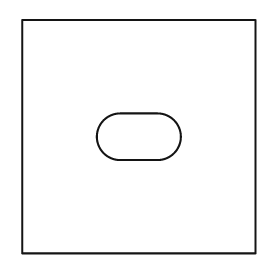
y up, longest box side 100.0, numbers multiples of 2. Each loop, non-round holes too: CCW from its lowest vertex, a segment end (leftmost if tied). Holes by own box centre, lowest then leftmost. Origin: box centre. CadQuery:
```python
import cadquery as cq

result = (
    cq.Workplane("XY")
    .moveTo(-50.0, -50.0)
    .lineTo(50.0, -50.0)
    .lineTo(50.0, 50.0)
    .lineTo(-50.0, 50.0)
    .close()
    .moveTo(-8.0, -10.0)
    .lineTo(8.0, -10.0)
    .threePointArc((18.0, 0.0), (8.0, 10.0))
    .lineTo(-8.0, 10.0)
    .threePointArc((-18.0, 0.0), (-8.0, -10.0))
    .close()
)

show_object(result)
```